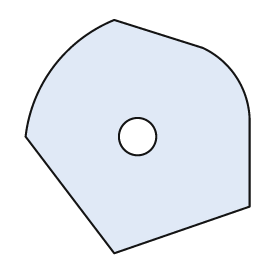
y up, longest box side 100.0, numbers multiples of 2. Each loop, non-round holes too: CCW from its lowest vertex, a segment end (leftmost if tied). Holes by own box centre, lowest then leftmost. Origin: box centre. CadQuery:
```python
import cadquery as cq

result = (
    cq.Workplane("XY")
    .moveTo(-10.0, -50.0)
    .lineTo(48.0, -30.0)
    .lineTo(48.0, 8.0)
    .threePointArc((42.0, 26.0), (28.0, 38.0))
    .lineTo(-10.0, 50.0)
    .threePointArc((-36.0, 30.0), (-48.0, 0.0))
    .close()
    .moveTo(0.0, 0.0)
    .circle(8.0)
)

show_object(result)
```